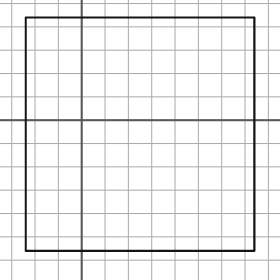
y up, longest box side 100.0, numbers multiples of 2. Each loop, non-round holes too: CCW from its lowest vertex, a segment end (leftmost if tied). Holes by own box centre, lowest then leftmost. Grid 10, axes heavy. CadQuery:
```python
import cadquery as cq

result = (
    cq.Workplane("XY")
    .moveTo(-24.0, -56.0)
    .lineTo(74.0, -56.0)
    .lineTo(74.0, 44.0)
    .lineTo(-24.0, 44.0)
    .close()
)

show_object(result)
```